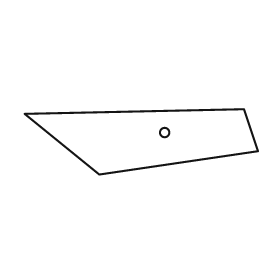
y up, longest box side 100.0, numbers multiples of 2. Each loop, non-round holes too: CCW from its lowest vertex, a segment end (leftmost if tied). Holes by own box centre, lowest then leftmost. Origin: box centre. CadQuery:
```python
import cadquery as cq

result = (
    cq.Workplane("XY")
    .moveTo(-18.0, -14.0)
    .lineTo(50.0, -4.0)
    .lineTo(44.0, 14.0)
    .lineTo(-50.0, 12.0)
    .close()
    .moveTo(10.0, 4.0)
    .circle(2.0)
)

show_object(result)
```